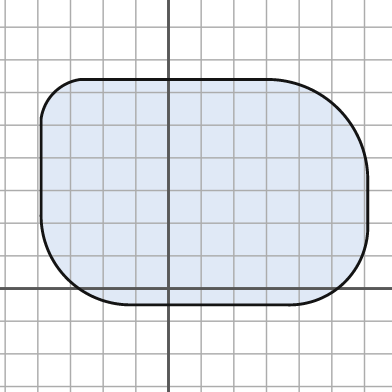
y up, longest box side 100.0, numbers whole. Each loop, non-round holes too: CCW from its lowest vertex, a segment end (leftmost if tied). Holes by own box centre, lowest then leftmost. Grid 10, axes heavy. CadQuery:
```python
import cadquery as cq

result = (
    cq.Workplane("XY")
    .moveTo(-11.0, -5.0)
    .lineTo(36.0, -5.0)
    .threePointArc((54.0, 2.0), (61.0, 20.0))
    .lineTo(61.0, 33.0)
    .threePointArc((52.0, 55.0), (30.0, 64.0))
    .lineTo(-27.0, 64.0)
    .threePointArc((-35.0, 60.0), (-39.0, 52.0))
    .lineTo(-39.0, 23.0)
    .threePointArc((-31.0, 3.0), (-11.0, -5.0))
    .close()
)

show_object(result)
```